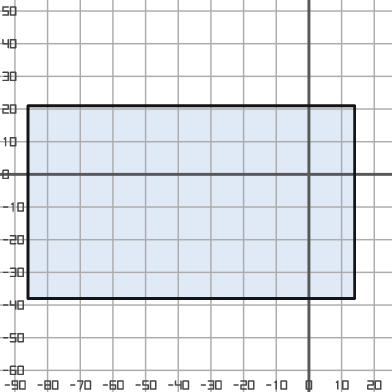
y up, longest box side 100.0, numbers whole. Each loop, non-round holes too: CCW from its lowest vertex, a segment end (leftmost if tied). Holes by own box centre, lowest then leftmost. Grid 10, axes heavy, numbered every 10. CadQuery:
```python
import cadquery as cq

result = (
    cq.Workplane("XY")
    .moveTo(-86.0, -38.0)
    .lineTo(14.0, -38.0)
    .lineTo(14.0, 21.0)
    .lineTo(-86.0, 21.0)
    .close()
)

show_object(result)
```